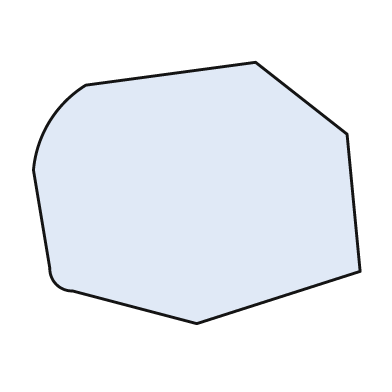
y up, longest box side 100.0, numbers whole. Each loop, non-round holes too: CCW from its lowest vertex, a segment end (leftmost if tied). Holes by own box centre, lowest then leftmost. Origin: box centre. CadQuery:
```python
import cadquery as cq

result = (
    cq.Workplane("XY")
    .moveTo(0.0, -40.0)
    .lineTo(50.0, -24.0)
    .lineTo(46.0, 18.0)
    .lineTo(18.0, 40.0)
    .lineTo(-34.0, 33.0)
    .threePointArc((-45.0, 22.0), (-50.0, 7.0))
    .lineTo(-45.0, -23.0)
    .threePointArc((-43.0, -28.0), (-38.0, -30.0))
    .close()
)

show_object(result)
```